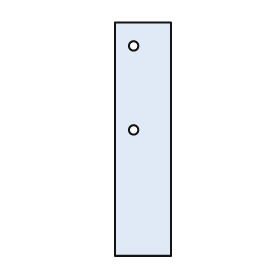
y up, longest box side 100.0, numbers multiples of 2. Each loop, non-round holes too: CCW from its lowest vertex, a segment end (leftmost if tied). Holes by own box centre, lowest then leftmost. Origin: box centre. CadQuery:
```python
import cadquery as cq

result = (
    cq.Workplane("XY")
    .moveTo(-12.0, -50.0)
    .lineTo(12.0, -50.0)
    .lineTo(12.0, 50.0)
    .lineTo(-12.0, 50.0)
    .close()
    .moveTo(-4.0, 4.0)
    .circle(2.0)
    .moveTo(-4.0, 40.0)
    .circle(2.0)
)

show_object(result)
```